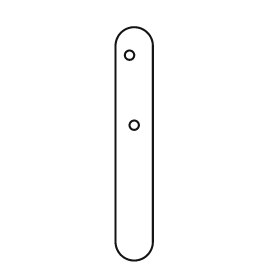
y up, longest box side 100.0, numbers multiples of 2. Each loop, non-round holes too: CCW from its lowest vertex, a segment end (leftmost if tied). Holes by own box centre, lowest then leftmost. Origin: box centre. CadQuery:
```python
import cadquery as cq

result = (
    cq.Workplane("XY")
    .moveTo(-8.0, -42.0)
    .threePointArc((0.0, -50.0), (8.0, -42.0))
    .lineTo(8.0, 42.0)
    .threePointArc((0.0, 50.0), (-8.0, 42.0))
    .close()
    .moveTo(0.0, 8.0)
    .circle(2.0)
    .moveTo(-2.0, 38.0)
    .circle(2.0)
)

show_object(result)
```